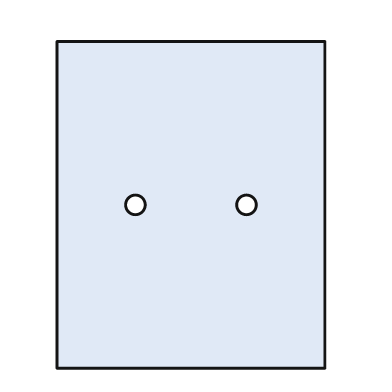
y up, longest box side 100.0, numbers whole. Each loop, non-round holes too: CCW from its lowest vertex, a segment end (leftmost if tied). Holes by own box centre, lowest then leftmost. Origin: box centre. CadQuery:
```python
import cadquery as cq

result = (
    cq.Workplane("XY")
    .moveTo(-41.0, -50.0)
    .lineTo(41.0, -50.0)
    .lineTo(41.0, 50.0)
    .lineTo(-41.0, 50.0)
    .close()
    .moveTo(-17.0, 0.0)
    .circle(3.0)
    .moveTo(17.0, 0.0)
    .circle(3.0)
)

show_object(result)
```